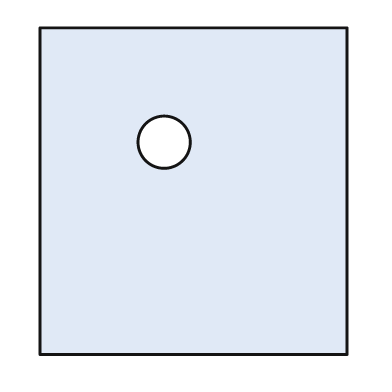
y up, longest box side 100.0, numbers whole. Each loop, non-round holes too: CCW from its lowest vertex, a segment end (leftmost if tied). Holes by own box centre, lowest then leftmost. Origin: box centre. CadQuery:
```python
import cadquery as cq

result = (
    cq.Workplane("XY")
    .moveTo(-47.0, -50.0)
    .lineTo(47.0, -50.0)
    .lineTo(47.0, 50.0)
    .lineTo(-47.0, 50.0)
    .close()
    .moveTo(-9.0, 15.0)
    .circle(8.0)
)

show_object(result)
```